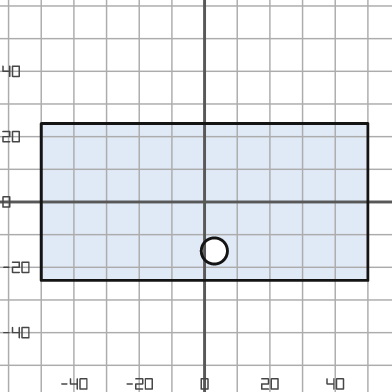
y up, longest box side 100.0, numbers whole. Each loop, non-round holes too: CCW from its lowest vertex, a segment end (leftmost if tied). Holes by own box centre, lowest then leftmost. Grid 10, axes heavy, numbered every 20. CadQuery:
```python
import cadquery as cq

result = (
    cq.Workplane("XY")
    .moveTo(-50.0, -24.0)
    .lineTo(50.0, -24.0)
    .lineTo(50.0, 24.0)
    .lineTo(-50.0, 24.0)
    .close()
    .moveTo(3.0, -15.0)
    .circle(4.0)
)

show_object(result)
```